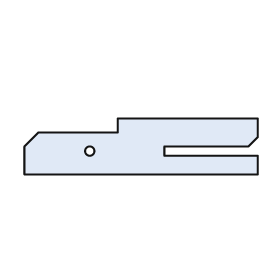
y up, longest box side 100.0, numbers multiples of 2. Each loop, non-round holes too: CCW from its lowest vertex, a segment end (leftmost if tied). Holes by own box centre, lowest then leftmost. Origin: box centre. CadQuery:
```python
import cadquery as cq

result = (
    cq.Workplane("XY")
    .moveTo(-50.0, -12.0)
    .lineTo(50.0, -12.0)
    .lineTo(50.0, -4.0)
    .lineTo(10.0, -4.0)
    .lineTo(10.0, 0.0)
    .lineTo(46.0, 0.0)
    .lineTo(50.0, 4.0)
    .lineTo(50.0, 12.0)
    .lineTo(-10.0, 12.0)
    .lineTo(-10.0, 6.0)
    .lineTo(-44.0, 6.0)
    .lineTo(-50.0, 0.0)
    .close()
    .moveTo(-22.0, -2.0)
    .circle(2.0)
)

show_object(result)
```